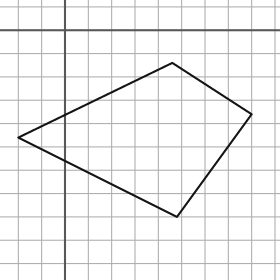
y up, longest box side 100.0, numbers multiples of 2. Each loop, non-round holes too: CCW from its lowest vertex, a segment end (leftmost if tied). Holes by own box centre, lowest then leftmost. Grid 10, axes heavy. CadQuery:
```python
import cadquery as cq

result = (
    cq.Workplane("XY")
    .moveTo(48.0, -80.0)
    .lineTo(80.0, -36.0)
    .lineTo(46.0, -14.0)
    .lineTo(-20.0, -46.0)
    .close()
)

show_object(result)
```